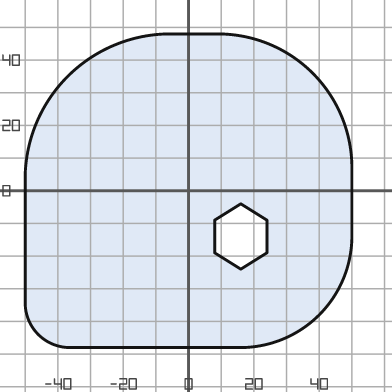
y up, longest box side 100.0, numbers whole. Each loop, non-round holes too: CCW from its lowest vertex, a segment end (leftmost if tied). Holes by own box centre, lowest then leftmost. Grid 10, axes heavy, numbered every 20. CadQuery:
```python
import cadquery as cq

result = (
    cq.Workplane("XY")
    .moveTo(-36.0, -48.0)
    .lineTo(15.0, -48.0)
    .threePointArc((40.0, -38.0), (50.0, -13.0))
    .lineTo(50.0, 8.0)
    .threePointArc((38.0, 36.0), (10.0, 48.0))
    .lineTo(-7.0, 48.0)
    .threePointArc((-37.0, 35.0), (-50.0, 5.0))
    .lineTo(-50.0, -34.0)
    .threePointArc((-46.0, -44.0), (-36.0, -48.0))
    .close()
    .moveTo(16.0, -24.0)
    .lineTo(24.0, -19.0)
    .lineTo(24.0, -9.0)
    .lineTo(16.0, -4.0)
    .lineTo(8.0, -9.0)
    .lineTo(8.0, -19.0)
    .close()
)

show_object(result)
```